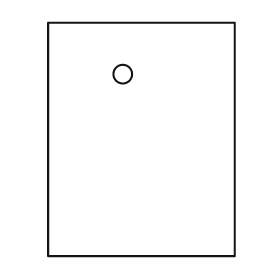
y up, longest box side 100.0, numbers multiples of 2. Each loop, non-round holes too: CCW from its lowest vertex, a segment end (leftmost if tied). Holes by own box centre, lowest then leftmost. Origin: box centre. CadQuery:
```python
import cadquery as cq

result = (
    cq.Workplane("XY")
    .moveTo(-40.0, -50.0)
    .lineTo(40.0, -50.0)
    .lineTo(40.0, 50.0)
    .lineTo(-40.0, 50.0)
    .close()
    .moveTo(-8.0, 28.0)
    .circle(4.0)
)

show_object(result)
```